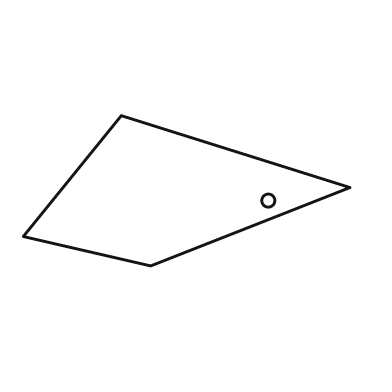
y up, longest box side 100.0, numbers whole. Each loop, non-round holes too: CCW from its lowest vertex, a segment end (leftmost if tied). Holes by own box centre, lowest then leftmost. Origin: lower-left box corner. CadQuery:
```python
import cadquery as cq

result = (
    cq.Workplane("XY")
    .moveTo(39.0, 0.0)
    .lineTo(100.0, 24.0)
    .lineTo(30.0, 46.0)
    .lineTo(0.0, 9.0)
    .close()
    .moveTo(75.0, 20.0)
    .circle(2.0)
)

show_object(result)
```